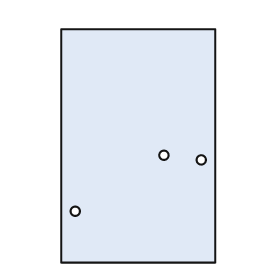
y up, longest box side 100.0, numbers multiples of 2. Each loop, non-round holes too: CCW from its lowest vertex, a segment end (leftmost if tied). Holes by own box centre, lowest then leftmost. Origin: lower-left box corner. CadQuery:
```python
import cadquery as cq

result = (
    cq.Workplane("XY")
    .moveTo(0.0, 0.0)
    .lineTo(66.0, 0.0)
    .lineTo(66.0, 100.0)
    .lineTo(0.0, 100.0)
    .close()
    .moveTo(6.0, 22.0)
    .circle(2.0)
    .moveTo(60.0, 44.0)
    .circle(2.0)
    .moveTo(44.0, 46.0)
    .circle(2.0)
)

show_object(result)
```